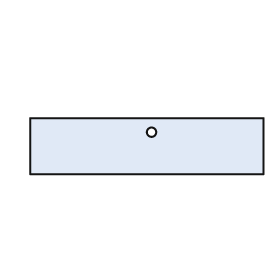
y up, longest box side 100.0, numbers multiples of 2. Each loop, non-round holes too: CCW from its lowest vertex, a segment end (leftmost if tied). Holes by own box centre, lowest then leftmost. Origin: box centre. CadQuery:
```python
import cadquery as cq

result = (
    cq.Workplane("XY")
    .moveTo(-50.0, -12.0)
    .lineTo(50.0, -12.0)
    .lineTo(50.0, 12.0)
    .lineTo(-50.0, 12.0)
    .close()
    .moveTo(2.0, 6.0)
    .circle(2.0)
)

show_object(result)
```